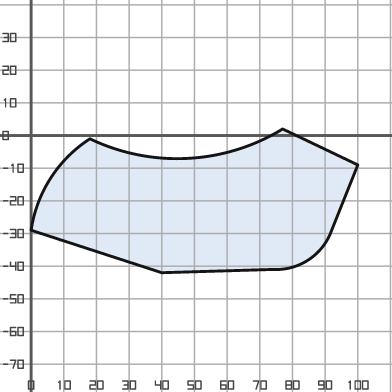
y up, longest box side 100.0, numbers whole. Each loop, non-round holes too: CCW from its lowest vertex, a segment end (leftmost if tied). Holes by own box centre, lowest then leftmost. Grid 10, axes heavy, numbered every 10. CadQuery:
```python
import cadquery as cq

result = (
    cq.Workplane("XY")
    .moveTo(40.0, -42.0)
    .lineTo(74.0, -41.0)
    .threePointArc((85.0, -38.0), (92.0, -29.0))
    .lineTo(100.0, -9.0)
    .lineTo(77.0, 2.0)
    .threePointArc((48.0, -7.0), (18.0, -1.0))
    .threePointArc((6.0, -13.0), (0.0, -29.0))
    .close()
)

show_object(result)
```